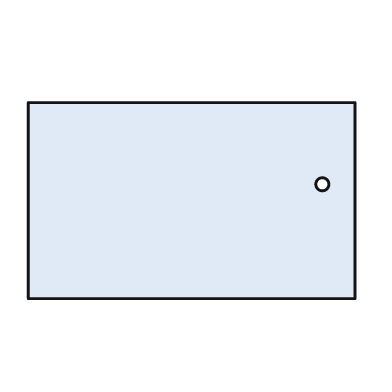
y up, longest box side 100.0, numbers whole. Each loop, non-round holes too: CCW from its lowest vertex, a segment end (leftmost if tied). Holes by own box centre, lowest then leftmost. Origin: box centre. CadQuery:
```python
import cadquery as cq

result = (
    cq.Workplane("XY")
    .moveTo(-50.0, -30.0)
    .lineTo(50.0, -30.0)
    .lineTo(50.0, 30.0)
    .lineTo(-50.0, 30.0)
    .close()
    .moveTo(40.0, 5.0)
    .circle(2.0)
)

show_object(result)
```